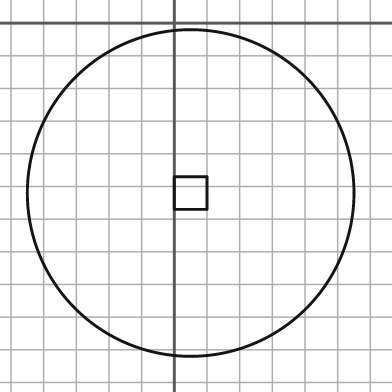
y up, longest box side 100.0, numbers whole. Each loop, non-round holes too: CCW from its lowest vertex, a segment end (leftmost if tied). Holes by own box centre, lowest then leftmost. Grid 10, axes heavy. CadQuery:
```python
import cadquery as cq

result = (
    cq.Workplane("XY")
    .moveTo(5.0, -52.0)
    .circle(50.0)
    .moveTo(0.0, -57.0)
    .lineTo(10.0, -57.0)
    .lineTo(10.0, -47.0)
    .lineTo(0.0, -47.0)
    .close()
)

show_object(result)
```